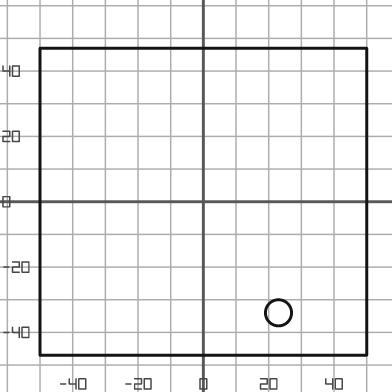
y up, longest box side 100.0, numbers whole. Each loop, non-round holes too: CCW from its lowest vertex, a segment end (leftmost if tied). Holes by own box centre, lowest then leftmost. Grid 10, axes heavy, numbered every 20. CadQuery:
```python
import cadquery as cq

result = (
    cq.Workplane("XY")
    .moveTo(-50.0, -47.0)
    .lineTo(50.0, -47.0)
    .lineTo(50.0, 47.0)
    .lineTo(-50.0, 47.0)
    .close()
    .moveTo(23.0, -34.0)
    .circle(4.0)
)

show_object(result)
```